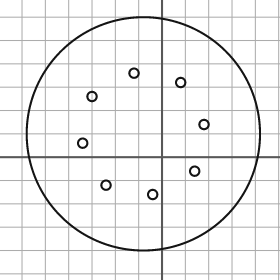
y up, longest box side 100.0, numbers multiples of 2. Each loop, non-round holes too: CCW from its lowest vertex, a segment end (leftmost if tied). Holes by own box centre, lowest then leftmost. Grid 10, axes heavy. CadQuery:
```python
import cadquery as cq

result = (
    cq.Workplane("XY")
    .moveTo(-8.0, 10.0)
    .circle(50.0)
    .moveTo(-4.0, -16.0)
    .circle(2.0)
    .moveTo(-24.0, -12.0)
    .circle(2.0)
    .moveTo(14.0, -6.0)
    .circle(2.0)
    .moveTo(-34.0, 6.0)
    .circle(2.0)
    .moveTo(18.0, 14.0)
    .circle(2.0)
    .moveTo(-30.0, 26.0)
    .circle(2.0)
    .moveTo(8.0, 32.0)
    .circle(2.0)
    .moveTo(-12.0, 36.0)
    .circle(2.0)
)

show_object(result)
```